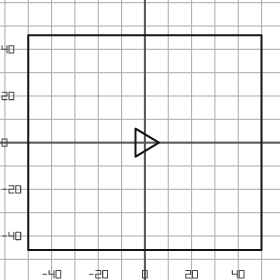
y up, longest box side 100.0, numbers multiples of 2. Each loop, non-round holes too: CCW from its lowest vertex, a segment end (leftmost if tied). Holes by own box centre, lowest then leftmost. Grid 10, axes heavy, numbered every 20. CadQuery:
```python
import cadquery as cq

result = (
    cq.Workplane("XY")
    .moveTo(-50.0, -46.0)
    .lineTo(50.0, -46.0)
    .lineTo(50.0, 46.0)
    .lineTo(-50.0, 46.0)
    .close()
    .moveTo(-4.0, -6.0)
    .lineTo(6.0, 0.0)
    .lineTo(-4.0, 6.0)
    .close()
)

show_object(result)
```